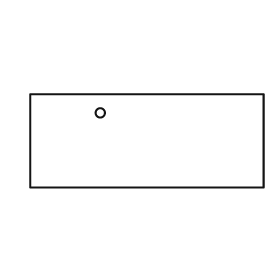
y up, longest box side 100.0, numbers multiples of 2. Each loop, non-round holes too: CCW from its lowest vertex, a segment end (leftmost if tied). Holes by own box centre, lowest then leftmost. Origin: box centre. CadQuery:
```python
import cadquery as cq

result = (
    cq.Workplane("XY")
    .moveTo(-50.0, -20.0)
    .lineTo(50.0, -20.0)
    .lineTo(50.0, 20.0)
    .lineTo(-50.0, 20.0)
    .close()
    .moveTo(-20.0, 12.0)
    .circle(2.0)
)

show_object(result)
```